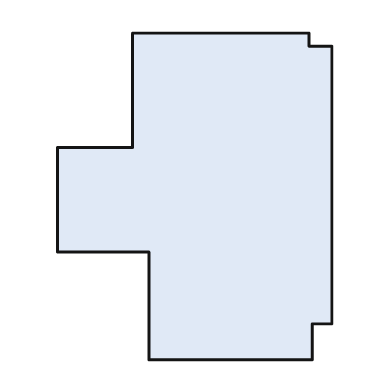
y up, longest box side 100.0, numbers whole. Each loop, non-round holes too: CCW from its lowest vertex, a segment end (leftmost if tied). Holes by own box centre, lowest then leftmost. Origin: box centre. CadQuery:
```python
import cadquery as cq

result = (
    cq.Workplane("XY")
    .moveTo(-14.0, -50.0)
    .lineTo(36.0, -50.0)
    .lineTo(36.0, -39.0)
    .lineTo(42.0, -39.0)
    .lineTo(42.0, 46.0)
    .lineTo(35.0, 46.0)
    .lineTo(35.0, 50.0)
    .lineTo(-19.0, 50.0)
    .lineTo(-19.0, 15.0)
    .lineTo(-42.0, 15.0)
    .lineTo(-42.0, -17.0)
    .lineTo(-14.0, -17.0)
    .close()
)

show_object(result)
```